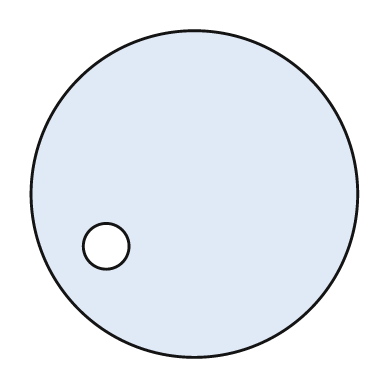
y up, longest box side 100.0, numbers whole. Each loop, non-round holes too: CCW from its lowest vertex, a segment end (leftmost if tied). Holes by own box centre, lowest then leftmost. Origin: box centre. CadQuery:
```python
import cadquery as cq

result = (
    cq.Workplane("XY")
    .moveTo(0.0, 0.0)
    .circle(50.0)
    .moveTo(-27.0, -16.0)
    .circle(7.0)
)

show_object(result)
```